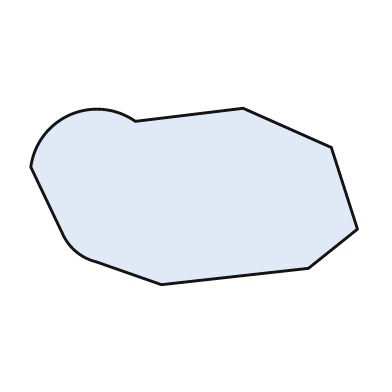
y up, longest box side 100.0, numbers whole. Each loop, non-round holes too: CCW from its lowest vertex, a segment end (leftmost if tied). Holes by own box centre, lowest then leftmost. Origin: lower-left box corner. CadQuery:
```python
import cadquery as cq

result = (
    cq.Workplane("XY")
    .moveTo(40.0, 0.0)
    .lineTo(85.0, 5.0)
    .lineTo(100.0, 17.0)
    .lineTo(92.0, 42.0)
    .lineTo(65.0, 54.0)
    .lineTo(32.0, 50.0)
    .threePointArc((12.0, 52.0), (0.0, 36.0))
    .lineTo(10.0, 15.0)
    .threePointArc((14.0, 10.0), (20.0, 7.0))
    .close()
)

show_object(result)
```